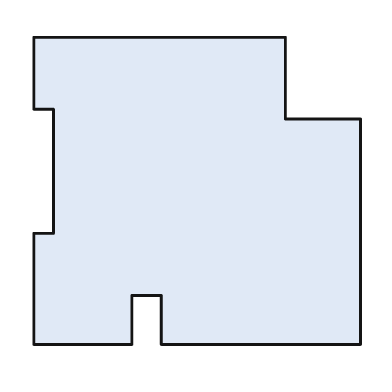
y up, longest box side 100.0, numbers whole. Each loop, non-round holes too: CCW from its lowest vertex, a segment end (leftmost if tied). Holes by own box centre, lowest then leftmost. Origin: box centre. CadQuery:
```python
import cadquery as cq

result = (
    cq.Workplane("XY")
    .moveTo(-50.0, -47.0)
    .lineTo(-20.0, -47.0)
    .lineTo(-20.0, -32.0)
    .lineTo(-11.0, -32.0)
    .lineTo(-11.0, -47.0)
    .lineTo(50.0, -47.0)
    .lineTo(50.0, 22.0)
    .lineTo(27.0, 22.0)
    .lineTo(27.0, 47.0)
    .lineTo(-50.0, 47.0)
    .lineTo(-50.0, 25.0)
    .lineTo(-44.0, 25.0)
    .lineTo(-44.0, -13.0)
    .lineTo(-50.0, -13.0)
    .close()
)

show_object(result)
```